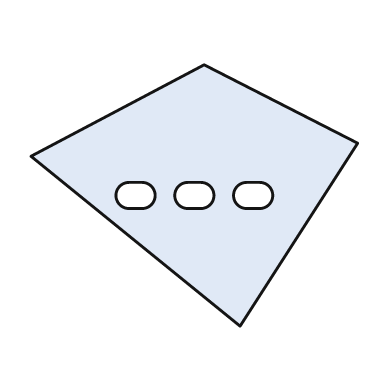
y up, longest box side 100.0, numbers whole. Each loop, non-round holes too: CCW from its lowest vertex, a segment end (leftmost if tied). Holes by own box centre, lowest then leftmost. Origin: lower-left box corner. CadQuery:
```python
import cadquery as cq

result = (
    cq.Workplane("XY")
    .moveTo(64.0, 0.0)
    .lineTo(100.0, 56.0)
    .lineTo(53.0, 80.0)
    .lineTo(0.0, 52.0)
    .close()
    .moveTo(30.0, 36.0)
    .lineTo(34.0, 36.0)
    .threePointArc((38.0, 40.0), (34.0, 44.0))
    .lineTo(30.0, 44.0)
    .threePointArc((26.0, 40.0), (30.0, 36.0))
    .close()
    .moveTo(48.0, 36.0)
    .lineTo(52.0, 36.0)
    .threePointArc((56.0, 40.0), (52.0, 44.0))
    .lineTo(48.0, 44.0)
    .threePointArc((44.0, 40.0), (48.0, 36.0))
    .close()
    .moveTo(66.0, 36.0)
    .lineTo(70.0, 36.0)
    .threePointArc((74.0, 40.0), (70.0, 44.0))
    .lineTo(66.0, 44.0)
    .threePointArc((62.0, 40.0), (66.0, 36.0))
    .close()
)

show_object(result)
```